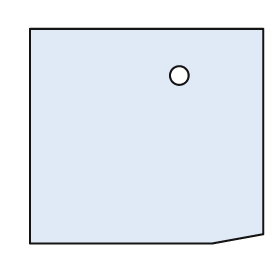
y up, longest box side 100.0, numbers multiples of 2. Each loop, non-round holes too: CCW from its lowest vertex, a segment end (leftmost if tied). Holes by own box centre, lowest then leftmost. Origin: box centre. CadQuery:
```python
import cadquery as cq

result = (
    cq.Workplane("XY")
    .moveTo(-50.0, -46.0)
    .lineTo(28.0, -46.0)
    .lineTo(50.0, -42.0)
    .lineTo(50.0, 46.0)
    .lineTo(-50.0, 46.0)
    .close()
    .moveTo(14.0, 26.0)
    .circle(4.0)
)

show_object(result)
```